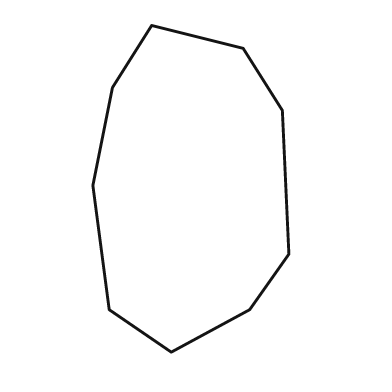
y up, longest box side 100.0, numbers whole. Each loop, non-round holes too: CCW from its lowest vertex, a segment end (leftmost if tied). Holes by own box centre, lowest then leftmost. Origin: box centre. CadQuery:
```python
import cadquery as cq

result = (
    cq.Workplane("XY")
    .moveTo(-6.0, -50.0)
    .lineTo(18.0, -37.0)
    .lineTo(30.0, -20.0)
    .lineTo(28.0, 24.0)
    .lineTo(16.0, 43.0)
    .lineTo(-12.0, 50.0)
    .lineTo(-24.0, 31.0)
    .lineTo(-30.0, 1.0)
    .lineTo(-25.0, -37.0)
    .close()
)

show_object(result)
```